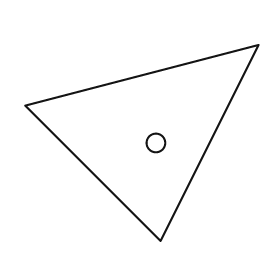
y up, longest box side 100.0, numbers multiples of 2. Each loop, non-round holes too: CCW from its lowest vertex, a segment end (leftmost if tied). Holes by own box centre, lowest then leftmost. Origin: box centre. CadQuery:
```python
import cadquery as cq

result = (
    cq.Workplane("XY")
    .moveTo(8.0, -42.0)
    .lineTo(50.0, 42.0)
    .lineTo(-50.0, 16.0)
    .close()
    .moveTo(6.0, 0.0)
    .circle(4.0)
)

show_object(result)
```